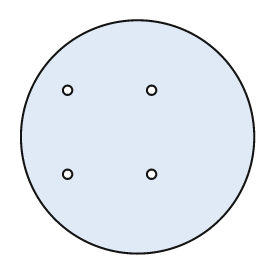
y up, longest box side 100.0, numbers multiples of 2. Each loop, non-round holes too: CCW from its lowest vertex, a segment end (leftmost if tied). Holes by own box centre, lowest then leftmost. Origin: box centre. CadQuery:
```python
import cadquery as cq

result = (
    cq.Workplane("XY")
    .moveTo(0.0, 0.0)
    .circle(50.0)
    .moveTo(-30.0, -16.0)
    .circle(2.0)
    .moveTo(6.0, -16.0)
    .circle(2.0)
    .moveTo(-30.0, 20.0)
    .circle(2.0)
    .moveTo(6.0, 20.0)
    .circle(2.0)
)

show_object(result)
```